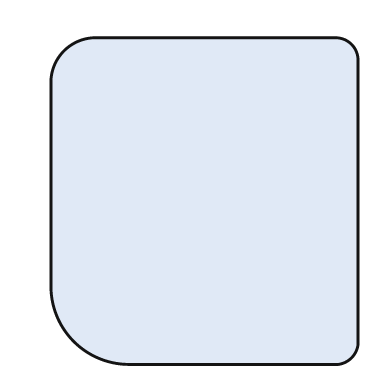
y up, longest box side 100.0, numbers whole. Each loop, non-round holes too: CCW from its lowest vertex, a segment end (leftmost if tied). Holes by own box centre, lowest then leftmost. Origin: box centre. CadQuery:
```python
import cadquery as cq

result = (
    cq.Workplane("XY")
    .moveTo(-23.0, -50.0)
    .lineTo(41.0, -50.0)
    .threePointArc((45.0, -48.0), (47.0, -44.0))
    .lineTo(47.0, 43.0)
    .threePointArc((45.0, 48.0), (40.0, 50.0))
    .lineTo(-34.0, 50.0)
    .threePointArc((-43.0, 46.0), (-47.0, 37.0))
    .lineTo(-47.0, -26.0)
    .threePointArc((-40.0, -43.0), (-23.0, -50.0))
    .close()
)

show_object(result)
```